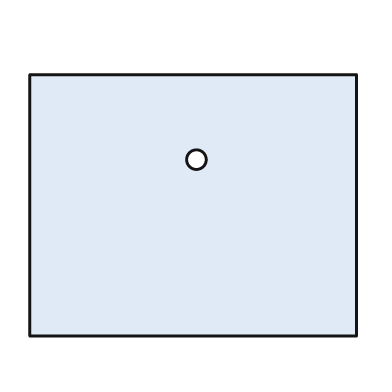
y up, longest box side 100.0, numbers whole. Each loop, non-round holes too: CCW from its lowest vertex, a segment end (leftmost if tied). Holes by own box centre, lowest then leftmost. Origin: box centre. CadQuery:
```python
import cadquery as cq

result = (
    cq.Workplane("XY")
    .moveTo(-50.0, -40.0)
    .lineTo(50.0, -40.0)
    .lineTo(50.0, 40.0)
    .lineTo(-50.0, 40.0)
    .close()
    .moveTo(1.0, 14.0)
    .circle(3.0)
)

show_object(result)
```